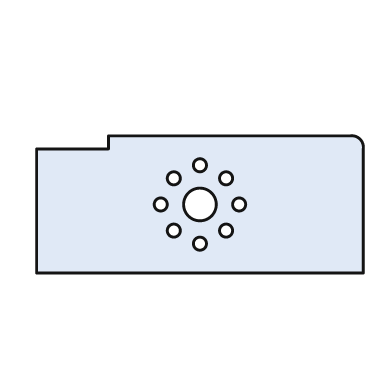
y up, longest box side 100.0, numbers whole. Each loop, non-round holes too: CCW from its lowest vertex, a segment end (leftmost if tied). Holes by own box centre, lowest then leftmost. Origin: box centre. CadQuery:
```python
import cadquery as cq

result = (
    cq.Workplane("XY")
    .moveTo(-50.0, -21.0)
    .lineTo(50.0, -21.0)
    .lineTo(50.0, 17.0)
    .threePointArc((49.0, 20.0), (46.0, 21.0))
    .lineTo(-28.0, 21.0)
    .lineTo(-28.0, 17.0)
    .lineTo(-50.0, 17.0)
    .close()
    .moveTo(0.0, -12.0)
    .circle(2.0)
    .moveTo(-8.0, -8.0)
    .circle(2.0)
    .moveTo(8.0, -8.0)
    .circle(2.0)
    .moveTo(-12.0, 0.0)
    .circle(2.0)
    .moveTo(0.0, 0.0)
    .circle(5.0)
    .moveTo(12.0, 0.0)
    .circle(2.0)
    .moveTo(-8.0, 8.0)
    .circle(2.0)
    .moveTo(8.0, 8.0)
    .circle(2.0)
    .moveTo(0.0, 12.0)
    .circle(2.0)
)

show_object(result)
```